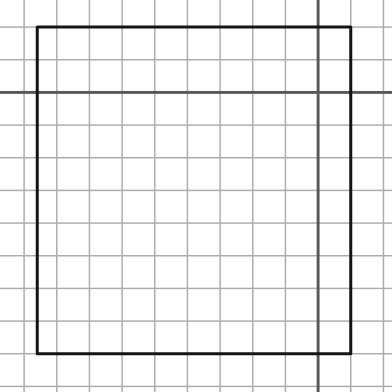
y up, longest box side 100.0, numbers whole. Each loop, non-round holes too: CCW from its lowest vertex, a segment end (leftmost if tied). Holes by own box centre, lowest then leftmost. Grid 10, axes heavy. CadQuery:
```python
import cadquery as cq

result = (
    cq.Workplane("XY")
    .moveTo(-86.0, -80.0)
    .lineTo(10.0, -80.0)
    .lineTo(10.0, 20.0)
    .lineTo(-86.0, 20.0)
    .close()
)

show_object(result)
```